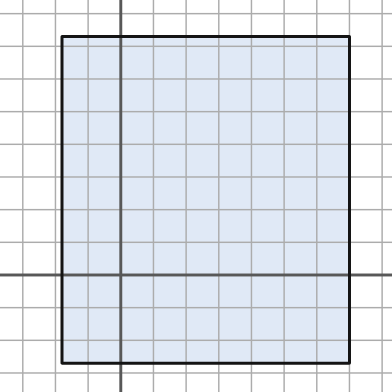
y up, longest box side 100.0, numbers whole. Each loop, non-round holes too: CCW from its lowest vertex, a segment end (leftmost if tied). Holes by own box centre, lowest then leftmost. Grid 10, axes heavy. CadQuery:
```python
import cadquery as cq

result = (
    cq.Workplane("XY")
    .moveTo(-18.0, -27.0)
    .lineTo(70.0, -27.0)
    .lineTo(70.0, 73.0)
    .lineTo(-18.0, 73.0)
    .close()
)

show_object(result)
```